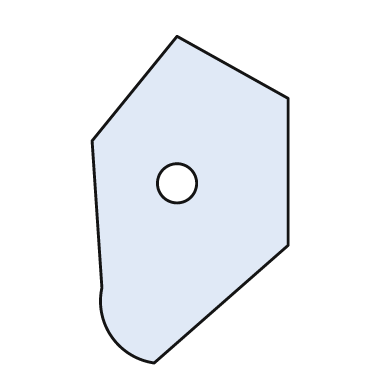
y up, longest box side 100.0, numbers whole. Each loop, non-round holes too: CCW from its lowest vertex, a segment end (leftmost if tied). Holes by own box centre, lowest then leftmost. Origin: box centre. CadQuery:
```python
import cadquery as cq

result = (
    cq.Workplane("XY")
    .moveTo(-11.0, -50.0)
    .lineTo(30.0, -14.0)
    .lineTo(30.0, 31.0)
    .lineTo(-4.0, 50.0)
    .lineTo(-30.0, 18.0)
    .lineTo(-27.0, -27.0)
    .threePointArc((-24.0, -42.0), (-11.0, -50.0))
    .close()
    .moveTo(-4.0, 5.0)
    .circle(6.0)
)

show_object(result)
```